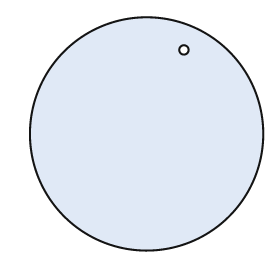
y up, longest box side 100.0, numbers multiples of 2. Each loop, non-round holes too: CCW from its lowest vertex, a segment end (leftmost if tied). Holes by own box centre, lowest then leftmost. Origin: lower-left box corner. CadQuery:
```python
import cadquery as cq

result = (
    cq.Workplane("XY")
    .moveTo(50.0, 50.0)
    .circle(50.0)
    .moveTo(66.0, 86.0)
    .circle(2.0)
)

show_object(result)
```